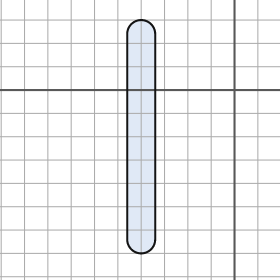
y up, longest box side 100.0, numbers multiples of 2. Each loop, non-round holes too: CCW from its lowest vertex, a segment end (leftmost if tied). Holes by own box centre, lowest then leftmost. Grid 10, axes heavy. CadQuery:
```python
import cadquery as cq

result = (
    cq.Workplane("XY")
    .moveTo(-46.0, -64.0)
    .threePointArc((-40.0, -70.0), (-34.0, -64.0))
    .lineTo(-34.0, 24.0)
    .threePointArc((-40.0, 30.0), (-46.0, 24.0))
    .close()
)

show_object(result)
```